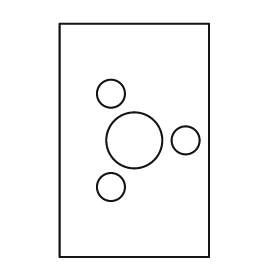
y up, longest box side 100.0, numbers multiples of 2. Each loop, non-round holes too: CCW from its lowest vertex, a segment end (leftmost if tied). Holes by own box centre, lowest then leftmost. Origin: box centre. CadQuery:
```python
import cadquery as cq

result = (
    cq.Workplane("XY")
    .moveTo(-32.0, -50.0)
    .lineTo(32.0, -50.0)
    .lineTo(32.0, 50.0)
    .lineTo(-32.0, 50.0)
    .close()
    .moveTo(-10.0, -20.0)
    .circle(6.0)
    .moveTo(0.0, 0.0)
    .circle(12.0)
    .moveTo(22.0, 0.0)
    .circle(6.0)
    .moveTo(-10.0, 20.0)
    .circle(6.0)
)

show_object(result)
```